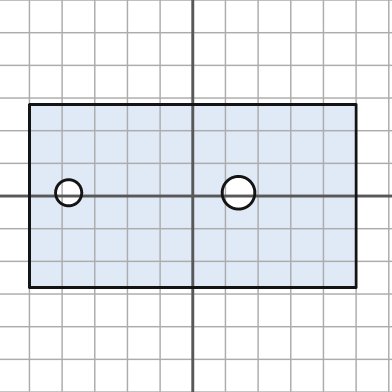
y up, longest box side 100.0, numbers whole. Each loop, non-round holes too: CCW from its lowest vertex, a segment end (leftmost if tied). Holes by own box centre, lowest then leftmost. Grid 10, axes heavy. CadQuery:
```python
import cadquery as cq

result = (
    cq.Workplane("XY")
    .moveTo(-50.0, -28.0)
    .lineTo(50.0, -28.0)
    .lineTo(50.0, 28.0)
    .lineTo(-50.0, 28.0)
    .close()
    .moveTo(-38.0, 1.0)
    .circle(4.0)
    .moveTo(14.0, 1.0)
    .circle(5.0)
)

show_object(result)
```